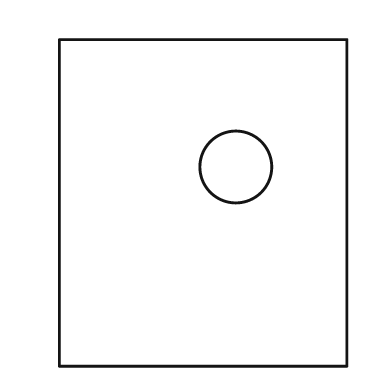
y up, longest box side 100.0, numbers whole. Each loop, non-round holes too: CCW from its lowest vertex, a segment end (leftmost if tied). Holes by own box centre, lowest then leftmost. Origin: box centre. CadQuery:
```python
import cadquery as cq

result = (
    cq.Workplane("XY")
    .moveTo(-44.0, -50.0)
    .lineTo(44.0, -50.0)
    .lineTo(44.0, 50.0)
    .lineTo(-44.0, 50.0)
    .close()
    .moveTo(10.0, 11.0)
    .circle(11.0)
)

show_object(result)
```